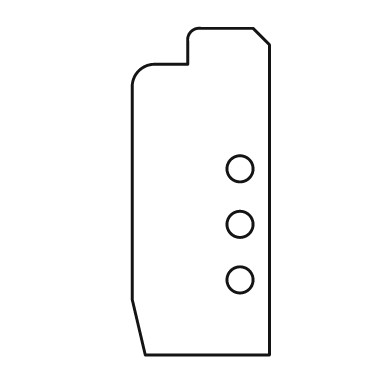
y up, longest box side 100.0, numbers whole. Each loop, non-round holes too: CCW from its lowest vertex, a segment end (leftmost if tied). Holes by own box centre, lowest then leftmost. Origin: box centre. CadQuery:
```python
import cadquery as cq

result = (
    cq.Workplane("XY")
    .moveTo(-17.0, -50.0)
    .lineTo(21.0, -50.0)
    .lineTo(21.0, 45.0)
    .lineTo(16.0, 50.0)
    .lineTo(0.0, 50.0)
    .threePointArc((-3.0, 49.0), (-4.0, 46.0))
    .lineTo(-4.0, 39.0)
    .lineTo(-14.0, 39.0)
    .threePointArc((-19.0, 37.0), (-21.0, 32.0))
    .lineTo(-21.0, -33.0)
    .close()
    .moveTo(12.0, -27.0)
    .circle(4.0)
    .moveTo(12.0, -10.0)
    .circle(4.0)
    .moveTo(12.0, 7.0)
    .circle(4.0)
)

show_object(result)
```